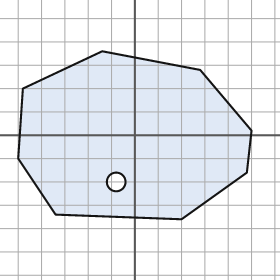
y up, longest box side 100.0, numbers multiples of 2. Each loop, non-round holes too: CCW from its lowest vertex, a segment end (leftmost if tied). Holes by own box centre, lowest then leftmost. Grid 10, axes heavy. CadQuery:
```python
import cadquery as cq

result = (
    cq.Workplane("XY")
    .moveTo(20.0, -36.0)
    .lineTo(48.0, -16.0)
    .lineTo(50.0, 2.0)
    .lineTo(28.0, 28.0)
    .lineTo(-14.0, 36.0)
    .lineTo(-48.0, 20.0)
    .lineTo(-50.0, -10.0)
    .lineTo(-34.0, -34.0)
    .close()
    .moveTo(-8.0, -20.0)
    .circle(4.0)
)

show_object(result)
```